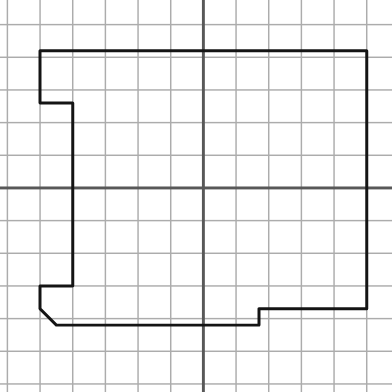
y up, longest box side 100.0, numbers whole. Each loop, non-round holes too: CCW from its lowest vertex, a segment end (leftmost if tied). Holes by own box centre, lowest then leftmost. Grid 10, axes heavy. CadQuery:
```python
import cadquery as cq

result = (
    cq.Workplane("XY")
    .moveTo(-45.0, -42.0)
    .lineTo(17.0, -42.0)
    .lineTo(17.0, -37.0)
    .lineTo(50.0, -37.0)
    .lineTo(50.0, 42.0)
    .lineTo(-50.0, 42.0)
    .lineTo(-50.0, 26.0)
    .lineTo(-40.0, 26.0)
    .lineTo(-40.0, -30.0)
    .lineTo(-50.0, -30.0)
    .lineTo(-50.0, -37.0)
    .close()
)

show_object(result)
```